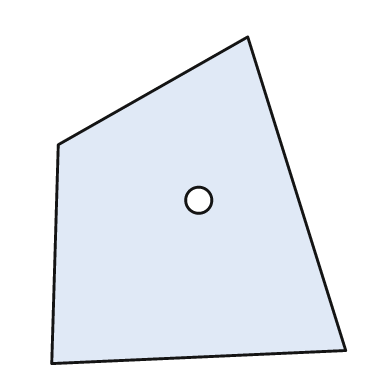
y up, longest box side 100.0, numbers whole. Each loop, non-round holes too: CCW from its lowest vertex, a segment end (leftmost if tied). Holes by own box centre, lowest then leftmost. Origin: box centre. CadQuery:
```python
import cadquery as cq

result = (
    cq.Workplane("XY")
    .moveTo(-45.0, -50.0)
    .lineTo(45.0, -46.0)
    .lineTo(15.0, 50.0)
    .lineTo(-43.0, 17.0)
    .close()
    .moveTo(0.0, 0.0)
    .circle(4.0)
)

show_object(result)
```